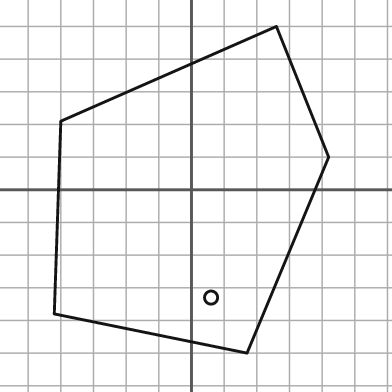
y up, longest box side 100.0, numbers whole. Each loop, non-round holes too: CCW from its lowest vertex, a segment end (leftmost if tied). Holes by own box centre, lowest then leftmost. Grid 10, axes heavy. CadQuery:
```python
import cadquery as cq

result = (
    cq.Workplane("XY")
    .moveTo(17.0, -50.0)
    .lineTo(42.0, 10.0)
    .lineTo(26.0, 50.0)
    .lineTo(-40.0, 21.0)
    .lineTo(-42.0, -38.0)
    .close()
    .moveTo(6.0, -33.0)
    .circle(2.0)
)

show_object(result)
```